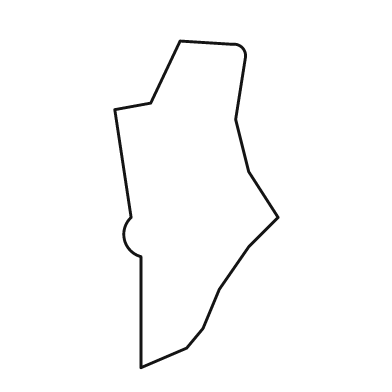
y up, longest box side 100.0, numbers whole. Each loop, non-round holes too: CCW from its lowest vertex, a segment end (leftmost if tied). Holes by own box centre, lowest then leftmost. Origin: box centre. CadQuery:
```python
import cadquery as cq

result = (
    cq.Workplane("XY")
    .moveTo(-17.0, -50.0)
    .lineTo(-3.0, -44.0)
    .lineTo(2.0, -38.0)
    .lineTo(7.0, -26.0)
    .lineTo(16.0, -13.0)
    .lineTo(25.0, -4.0)
    .lineTo(16.0, 10.0)
    .lineTo(12.0, 26.0)
    .lineTo(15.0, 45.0)
    .threePointArc((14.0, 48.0), (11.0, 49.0))
    .lineTo(-5.0, 50.0)
    .lineTo(-14.0, 31.0)
    .lineTo(-25.0, 29.0)
    .lineTo(-20.0, -4.0)
    .threePointArc((-22.0, -11.0), (-17.0, -16.0))
    .close()
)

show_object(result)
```